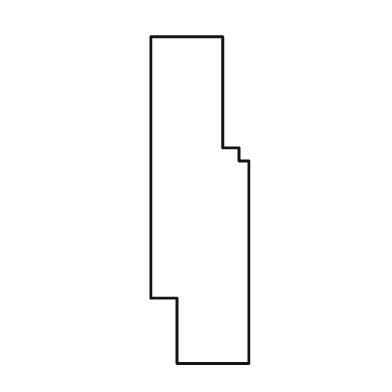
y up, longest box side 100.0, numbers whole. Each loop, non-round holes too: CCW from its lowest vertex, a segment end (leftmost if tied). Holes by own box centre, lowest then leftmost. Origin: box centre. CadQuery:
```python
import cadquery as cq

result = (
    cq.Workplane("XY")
    .moveTo(-7.0, -50.0)
    .lineTo(15.0, -50.0)
    .lineTo(15.0, 12.0)
    .lineTo(12.0, 12.0)
    .lineTo(12.0, 16.0)
    .lineTo(7.0, 16.0)
    .lineTo(7.0, 50.0)
    .lineTo(-15.0, 50.0)
    .lineTo(-15.0, -30.0)
    .lineTo(-7.0, -30.0)
    .close()
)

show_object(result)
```